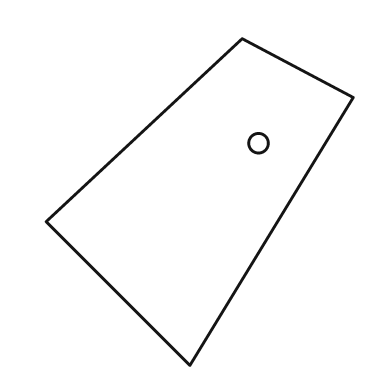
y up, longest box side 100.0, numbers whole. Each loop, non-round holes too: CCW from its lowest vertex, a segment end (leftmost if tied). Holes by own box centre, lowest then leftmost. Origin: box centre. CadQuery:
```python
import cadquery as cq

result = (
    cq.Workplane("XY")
    .moveTo(-3.0, -50.0)
    .lineTo(47.0, 32.0)
    .lineTo(13.0, 50.0)
    .lineTo(-47.0, -6.0)
    .close()
    .moveTo(18.0, 18.0)
    .circle(3.0)
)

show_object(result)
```